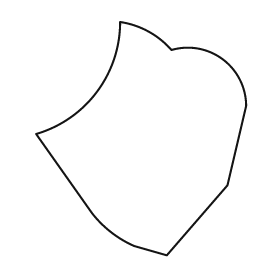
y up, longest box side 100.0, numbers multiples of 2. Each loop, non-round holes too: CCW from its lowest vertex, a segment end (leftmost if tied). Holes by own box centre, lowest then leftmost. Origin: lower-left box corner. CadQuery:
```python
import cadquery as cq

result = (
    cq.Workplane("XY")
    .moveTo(56.0, 0.0)
    .lineTo(82.0, 30.0)
    .lineTo(90.0, 64.0)
    .threePointArc((80.0, 84.0), (58.0, 88.0))
    .threePointArc((48.0, 96.0), (36.0, 100.0))
    .threePointArc((26.0, 70.0), (0.0, 52.0))
    .lineTo(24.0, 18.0)
    .threePointArc((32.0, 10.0), (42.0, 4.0))
    .close()
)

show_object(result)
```